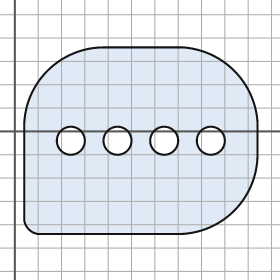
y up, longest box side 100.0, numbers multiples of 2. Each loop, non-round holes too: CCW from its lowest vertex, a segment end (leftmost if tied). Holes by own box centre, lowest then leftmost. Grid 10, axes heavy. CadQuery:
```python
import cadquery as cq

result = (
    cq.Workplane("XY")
    .moveTo(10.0, -44.0)
    .lineTo(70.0, -44.0)
    .threePointArc((94.0, -34.0), (104.0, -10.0))
    .lineTo(104.0, 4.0)
    .threePointArc((94.0, 26.0), (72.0, 36.0))
    .lineTo(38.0, 36.0)
    .threePointArc((14.0, 26.0), (4.0, 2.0))
    .lineTo(4.0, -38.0)
    .threePointArc((6.0, -42.0), (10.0, -44.0))
    .close()
    .moveTo(24.0, -4.0)
    .circle(6.0)
    .moveTo(44.0, -4.0)
    .circle(6.0)
    .moveTo(64.0, -4.0)
    .circle(6.0)
    .moveTo(84.0, -4.0)
    .circle(6.0)
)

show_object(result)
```